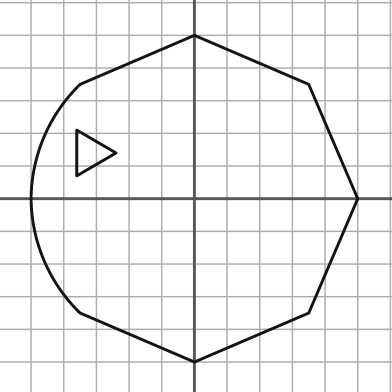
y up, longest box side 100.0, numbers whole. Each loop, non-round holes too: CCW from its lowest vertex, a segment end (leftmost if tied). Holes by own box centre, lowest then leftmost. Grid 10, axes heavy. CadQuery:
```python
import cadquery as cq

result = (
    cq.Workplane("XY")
    .moveTo(0.0, -50.0)
    .lineTo(35.0, -35.0)
    .lineTo(50.0, 0.0)
    .lineTo(35.0, 35.0)
    .lineTo(0.0, 50.0)
    .lineTo(-35.0, 35.0)
    .threePointArc((-46.0, 19.0), (-50.0, 0.0))
    .threePointArc((-46.0, -19.0), (-35.0, -35.0))
    .close()
    .moveTo(-36.0, 7.0)
    .lineTo(-24.0, 14.0)
    .lineTo(-36.0, 21.0)
    .close()
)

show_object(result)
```